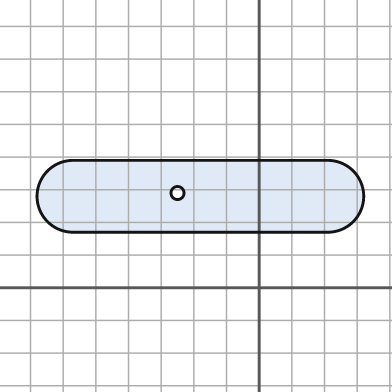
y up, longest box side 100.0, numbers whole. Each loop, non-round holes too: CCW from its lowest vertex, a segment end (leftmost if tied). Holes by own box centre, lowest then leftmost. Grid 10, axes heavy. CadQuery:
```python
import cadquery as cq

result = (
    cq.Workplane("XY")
    .moveTo(-57.0, 17.0)
    .lineTo(21.0, 17.0)
    .threePointArc((32.0, 28.0), (21.0, 39.0))
    .lineTo(-57.0, 39.0)
    .threePointArc((-68.0, 28.0), (-57.0, 17.0))
    .close()
    .moveTo(-25.0, 29.0)
    .circle(2.0)
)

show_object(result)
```